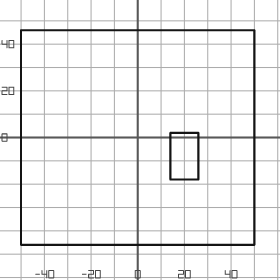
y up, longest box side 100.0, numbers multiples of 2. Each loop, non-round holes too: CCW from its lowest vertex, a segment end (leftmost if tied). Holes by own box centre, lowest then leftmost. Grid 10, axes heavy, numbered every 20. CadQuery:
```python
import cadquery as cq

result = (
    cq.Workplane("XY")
    .moveTo(-50.0, -46.0)
    .lineTo(50.0, -46.0)
    .lineTo(50.0, 46.0)
    .lineTo(-50.0, 46.0)
    .close()
    .moveTo(14.0, -18.0)
    .lineTo(26.0, -18.0)
    .lineTo(26.0, 2.0)
    .lineTo(14.0, 2.0)
    .close()
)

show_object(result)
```